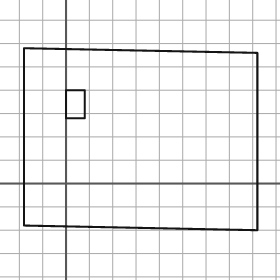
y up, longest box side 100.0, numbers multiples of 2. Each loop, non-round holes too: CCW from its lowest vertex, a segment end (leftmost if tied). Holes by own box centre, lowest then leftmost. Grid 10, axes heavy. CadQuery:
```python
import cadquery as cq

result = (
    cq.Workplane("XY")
    .moveTo(82.0, -20.0)
    .lineTo(82.0, 56.0)
    .lineTo(-18.0, 58.0)
    .lineTo(-18.0, -18.0)
    .close()
    .moveTo(0.0, 28.0)
    .lineTo(8.0, 28.0)
    .lineTo(8.0, 40.0)
    .lineTo(0.0, 40.0)
    .close()
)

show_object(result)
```